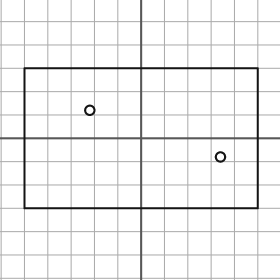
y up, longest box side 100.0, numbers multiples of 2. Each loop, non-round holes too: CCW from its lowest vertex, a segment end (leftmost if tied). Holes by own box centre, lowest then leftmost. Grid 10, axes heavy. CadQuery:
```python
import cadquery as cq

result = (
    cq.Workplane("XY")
    .moveTo(-50.0, -30.0)
    .lineTo(50.0, -30.0)
    .lineTo(50.0, 30.0)
    .lineTo(-50.0, 30.0)
    .close()
    .moveTo(34.0, -8.0)
    .circle(2.0)
    .moveTo(-22.0, 12.0)
    .circle(2.0)
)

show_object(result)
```